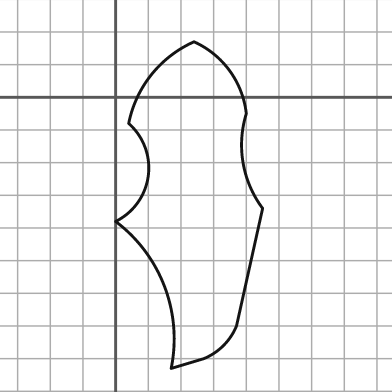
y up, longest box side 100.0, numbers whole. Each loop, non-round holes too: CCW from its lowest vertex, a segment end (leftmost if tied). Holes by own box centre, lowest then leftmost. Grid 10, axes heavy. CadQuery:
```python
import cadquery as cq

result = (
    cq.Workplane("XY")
    .moveTo(17.0, -83.0)
    .lineTo(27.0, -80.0)
    .threePointArc((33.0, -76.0), (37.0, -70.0))
    .lineTo(45.0, -34.0)
    .threePointArc((39.0, -20.0), (40.0, -5.0))
    .threePointArc((35.0, 8.0), (24.0, 17.0))
    .threePointArc((11.0, 7.0), (4.0, -8.0))
    .threePointArc((10.0, -24.0), (0.0, -38.0))
    .threePointArc((15.0, -58.0), (17.0, -83.0))
    .close()
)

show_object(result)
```